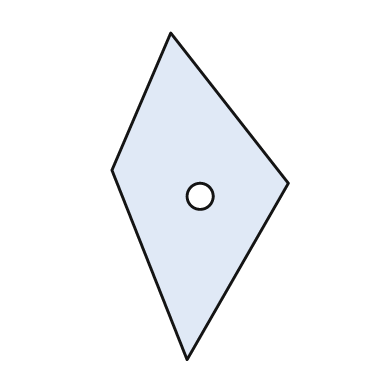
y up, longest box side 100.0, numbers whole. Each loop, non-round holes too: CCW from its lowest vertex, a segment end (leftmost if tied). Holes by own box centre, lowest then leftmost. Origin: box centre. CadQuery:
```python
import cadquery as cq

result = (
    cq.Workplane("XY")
    .moveTo(-4.0, -50.0)
    .lineTo(27.0, 4.0)
    .lineTo(-9.0, 50.0)
    .lineTo(-27.0, 8.0)
    .close()
    .moveTo(0.0, 0.0)
    .circle(4.0)
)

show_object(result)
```